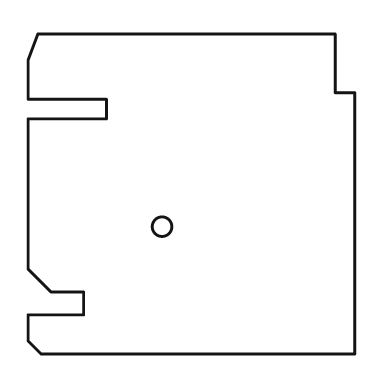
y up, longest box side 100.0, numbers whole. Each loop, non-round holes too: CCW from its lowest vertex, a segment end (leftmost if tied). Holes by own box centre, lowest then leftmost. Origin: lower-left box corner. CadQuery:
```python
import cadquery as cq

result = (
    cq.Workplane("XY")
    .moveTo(4.0, 0.0)
    .lineTo(100.0, 0.0)
    .lineTo(100.0, 80.0)
    .lineTo(94.0, 80.0)
    .lineTo(94.0, 98.0)
    .lineTo(3.0, 98.0)
    .lineTo(0.0, 90.0)
    .lineTo(0.0, 78.0)
    .lineTo(24.0, 78.0)
    .lineTo(24.0, 72.0)
    .lineTo(0.0, 72.0)
    .lineTo(0.0, 26.0)
    .lineTo(7.0, 19.0)
    .lineTo(17.0, 19.0)
    .lineTo(17.0, 12.0)
    .lineTo(0.0, 12.0)
    .lineTo(0.0, 4.0)
    .close()
    .moveTo(41.0, 39.0)
    .circle(3.0)
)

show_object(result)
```